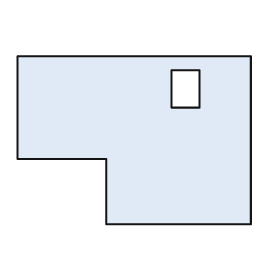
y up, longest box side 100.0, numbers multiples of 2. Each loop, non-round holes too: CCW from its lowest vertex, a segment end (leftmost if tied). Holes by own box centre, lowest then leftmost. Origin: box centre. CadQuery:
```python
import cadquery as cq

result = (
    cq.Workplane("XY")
    .moveTo(-12.0, -36.0)
    .lineTo(50.0, -36.0)
    .lineTo(50.0, 36.0)
    .lineTo(-50.0, 36.0)
    .lineTo(-50.0, -8.0)
    .lineTo(-12.0, -8.0)
    .close()
    .moveTo(16.0, 14.0)
    .lineTo(28.0, 14.0)
    .lineTo(28.0, 30.0)
    .lineTo(16.0, 30.0)
    .close()
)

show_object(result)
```